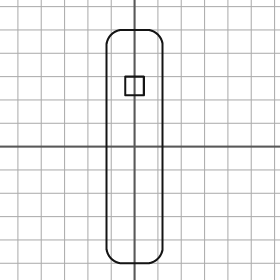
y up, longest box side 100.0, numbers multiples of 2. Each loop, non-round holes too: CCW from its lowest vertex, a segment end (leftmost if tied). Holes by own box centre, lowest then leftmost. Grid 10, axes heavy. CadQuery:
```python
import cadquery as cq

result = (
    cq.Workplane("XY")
    .moveTo(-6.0, -50.0)
    .lineTo(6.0, -50.0)
    .threePointArc((10.0, -48.0), (12.0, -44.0))
    .lineTo(12.0, 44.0)
    .threePointArc((10.0, 48.0), (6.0, 50.0))
    .lineTo(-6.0, 50.0)
    .threePointArc((-10.0, 48.0), (-12.0, 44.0))
    .lineTo(-12.0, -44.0)
    .threePointArc((-10.0, -48.0), (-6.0, -50.0))
    .close()
    .moveTo(-4.0, 22.0)
    .lineTo(4.0, 22.0)
    .lineTo(4.0, 30.0)
    .lineTo(-4.0, 30.0)
    .close()
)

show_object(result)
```